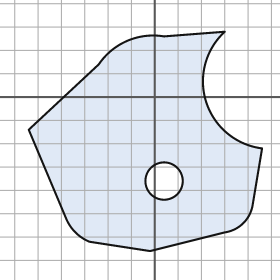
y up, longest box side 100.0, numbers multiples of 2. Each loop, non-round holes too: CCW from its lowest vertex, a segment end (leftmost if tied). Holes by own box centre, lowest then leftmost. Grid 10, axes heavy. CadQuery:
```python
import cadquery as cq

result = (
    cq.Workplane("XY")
    .moveTo(-2.0, -66.0)
    .lineTo(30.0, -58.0)
    .threePointArc((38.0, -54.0), (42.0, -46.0))
    .lineTo(46.0, -22.0)
    .threePointArc((22.0, -2.0), (30.0, 28.0))
    .lineTo(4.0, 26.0)
    .threePointArc((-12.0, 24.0), (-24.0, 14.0))
    .lineTo(-54.0, -14.0)
    .lineTo(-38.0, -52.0)
    .threePointArc((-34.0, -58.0), (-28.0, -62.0))
    .close()
    .moveTo(4.0, -36.0)
    .circle(8.0)
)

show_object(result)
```